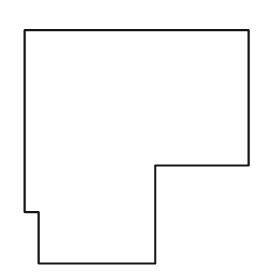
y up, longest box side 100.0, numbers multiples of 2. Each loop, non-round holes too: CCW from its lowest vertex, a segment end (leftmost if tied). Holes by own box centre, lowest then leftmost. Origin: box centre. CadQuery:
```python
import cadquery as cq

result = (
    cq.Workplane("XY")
    .moveTo(-42.0, -50.0)
    .lineTo(8.0, -50.0)
    .lineTo(8.0, -8.0)
    .lineTo(48.0, -8.0)
    .lineTo(48.0, 50.0)
    .lineTo(-48.0, 50.0)
    .lineTo(-48.0, -28.0)
    .lineTo(-42.0, -28.0)
    .close()
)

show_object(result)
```